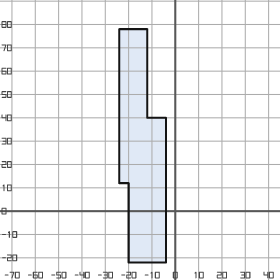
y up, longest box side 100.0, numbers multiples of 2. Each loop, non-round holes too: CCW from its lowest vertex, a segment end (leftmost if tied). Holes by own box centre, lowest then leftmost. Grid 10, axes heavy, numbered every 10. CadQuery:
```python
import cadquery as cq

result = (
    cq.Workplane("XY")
    .moveTo(-20.0, -22.0)
    .lineTo(-4.0, -22.0)
    .lineTo(-4.0, 40.0)
    .lineTo(-12.0, 40.0)
    .lineTo(-12.0, 78.0)
    .lineTo(-24.0, 78.0)
    .lineTo(-24.0, 12.0)
    .lineTo(-20.0, 12.0)
    .close()
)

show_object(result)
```